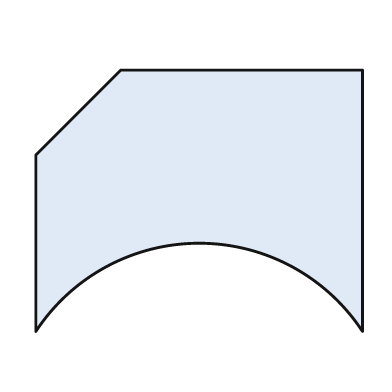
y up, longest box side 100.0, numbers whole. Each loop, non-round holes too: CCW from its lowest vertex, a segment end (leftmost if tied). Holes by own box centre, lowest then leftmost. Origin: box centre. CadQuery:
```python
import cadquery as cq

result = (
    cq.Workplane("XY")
    .moveTo(-50.0, -40.0)
    .threePointArc((0.0, -13.0), (50.0, -40.0))
    .lineTo(50.0, 40.0)
    .lineTo(-24.0, 40.0)
    .lineTo(-50.0, 14.0)
    .close()
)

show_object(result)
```